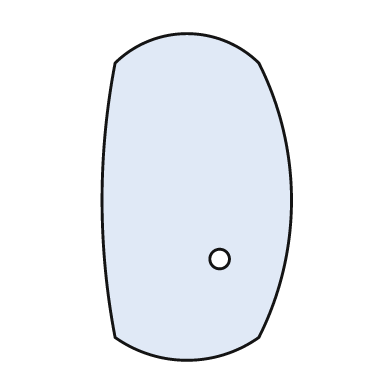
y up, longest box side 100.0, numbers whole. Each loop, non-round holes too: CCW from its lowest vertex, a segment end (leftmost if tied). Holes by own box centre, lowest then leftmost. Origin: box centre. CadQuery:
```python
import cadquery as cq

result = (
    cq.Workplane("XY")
    .moveTo(-25.0, -43.0)
    .threePointArc((-3.0, -50.0), (19.0, -43.0))
    .threePointArc((29.0, -1.0), (19.0, 41.0))
    .threePointArc((-3.0, 50.0), (-25.0, 41.0))
    .threePointArc((-29.0, -1.0), (-25.0, -43.0))
    .close()
    .moveTo(7.0, -19.0)
    .circle(3.0)
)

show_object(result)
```